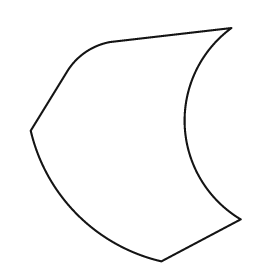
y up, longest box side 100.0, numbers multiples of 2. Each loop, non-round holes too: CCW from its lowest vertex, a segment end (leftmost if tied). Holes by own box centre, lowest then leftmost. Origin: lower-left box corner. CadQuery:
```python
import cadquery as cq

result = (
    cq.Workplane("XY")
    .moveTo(56.0, 0.0)
    .lineTo(90.0, 18.0)
    .threePointArc((66.0, 58.0), (86.0, 100.0))
    .lineTo(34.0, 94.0)
    .threePointArc((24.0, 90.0), (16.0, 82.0))
    .lineTo(0.0, 56.0)
    .threePointArc((20.0, 20.0), (56.0, 0.0))
    .close()
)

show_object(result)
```